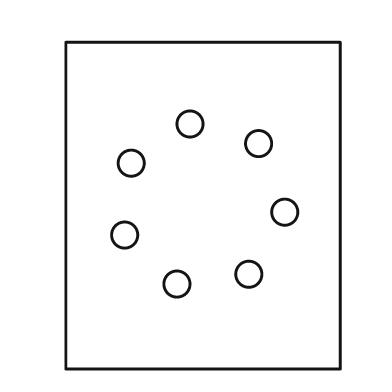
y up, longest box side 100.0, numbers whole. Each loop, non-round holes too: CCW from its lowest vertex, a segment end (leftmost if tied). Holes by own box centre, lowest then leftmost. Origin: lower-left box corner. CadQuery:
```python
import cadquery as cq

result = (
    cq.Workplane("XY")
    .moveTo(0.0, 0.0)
    .lineTo(84.0, 0.0)
    .lineTo(84.0, 100.0)
    .lineTo(0.0, 100.0)
    .close()
    .moveTo(34.0, 26.0)
    .circle(4.0)
    .moveTo(56.0, 29.0)
    .circle(4.0)
    .moveTo(18.0, 41.0)
    .circle(4.0)
    .moveTo(67.0, 48.0)
    .circle(4.0)
    .moveTo(20.0, 63.0)
    .circle(4.0)
    .moveTo(59.0, 69.0)
    .circle(4.0)
    .moveTo(38.0, 75.0)
    .circle(4.0)
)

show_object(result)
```